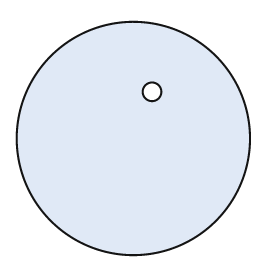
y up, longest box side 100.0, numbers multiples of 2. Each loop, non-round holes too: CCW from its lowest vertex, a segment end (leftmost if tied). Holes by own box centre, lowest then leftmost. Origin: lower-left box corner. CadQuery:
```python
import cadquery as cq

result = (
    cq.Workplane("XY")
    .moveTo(50.0, 50.0)
    .circle(50.0)
    .moveTo(58.0, 70.0)
    .circle(4.0)
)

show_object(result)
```